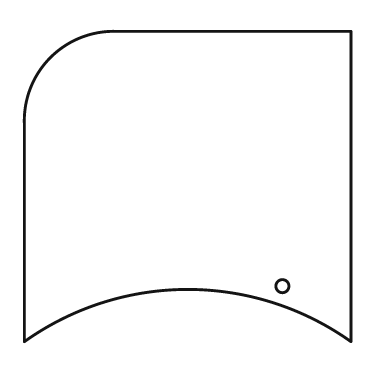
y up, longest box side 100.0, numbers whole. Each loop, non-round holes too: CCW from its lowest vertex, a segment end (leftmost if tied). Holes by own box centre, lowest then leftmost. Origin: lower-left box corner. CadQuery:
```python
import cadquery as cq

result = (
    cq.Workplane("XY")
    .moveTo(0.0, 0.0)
    .threePointArc((50.0, 16.0), (100.0, 0.0))
    .lineTo(100.0, 95.0)
    .lineTo(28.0, 95.0)
    .threePointArc((8.0, 87.0), (0.0, 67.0))
    .close()
    .moveTo(79.0, 17.0)
    .circle(2.0)
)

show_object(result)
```